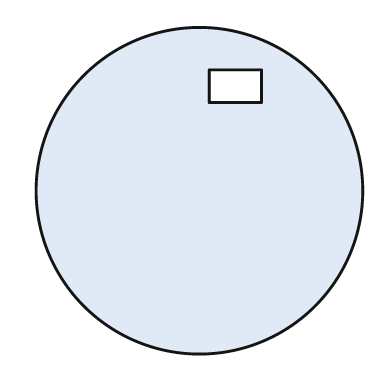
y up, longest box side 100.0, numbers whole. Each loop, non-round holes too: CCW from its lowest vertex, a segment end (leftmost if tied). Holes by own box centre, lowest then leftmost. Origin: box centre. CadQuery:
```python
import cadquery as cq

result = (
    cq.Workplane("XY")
    .moveTo(0.0, 0.0)
    .circle(50.0)
    .moveTo(3.0, 27.0)
    .lineTo(19.0, 27.0)
    .lineTo(19.0, 37.0)
    .lineTo(3.0, 37.0)
    .close()
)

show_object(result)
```